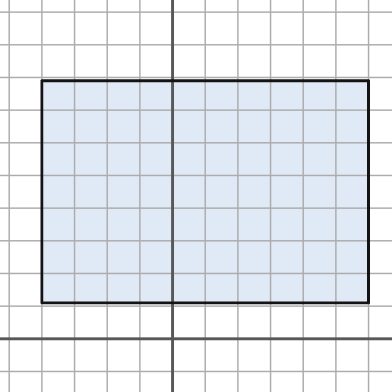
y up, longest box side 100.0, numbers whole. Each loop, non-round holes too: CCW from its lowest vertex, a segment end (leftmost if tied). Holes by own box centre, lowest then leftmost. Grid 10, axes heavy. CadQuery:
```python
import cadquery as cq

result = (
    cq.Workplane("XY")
    .moveTo(-40.0, 11.0)
    .lineTo(60.0, 11.0)
    .lineTo(60.0, 79.0)
    .lineTo(-40.0, 79.0)
    .close()
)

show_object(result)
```